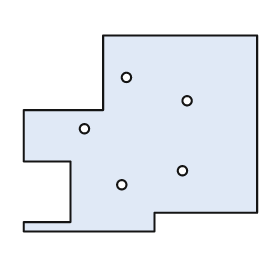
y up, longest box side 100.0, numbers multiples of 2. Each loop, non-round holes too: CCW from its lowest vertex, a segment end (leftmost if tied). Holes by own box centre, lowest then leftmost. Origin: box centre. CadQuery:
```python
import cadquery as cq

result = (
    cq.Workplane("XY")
    .moveTo(-50.0, -42.0)
    .lineTo(6.0, -42.0)
    .lineTo(6.0, -34.0)
    .lineTo(50.0, -34.0)
    .lineTo(50.0, 42.0)
    .lineTo(-16.0, 42.0)
    .lineTo(-16.0, 10.0)
    .lineTo(-50.0, 10.0)
    .lineTo(-50.0, -12.0)
    .lineTo(-30.0, -12.0)
    .lineTo(-30.0, -38.0)
    .lineTo(-50.0, -38.0)
    .close()
    .moveTo(-8.0, -22.0)
    .circle(2.0)
    .moveTo(18.0, -16.0)
    .circle(2.0)
    .moveTo(-24.0, 2.0)
    .circle(2.0)
    .moveTo(20.0, 14.0)
    .circle(2.0)
    .moveTo(-6.0, 24.0)
    .circle(2.0)
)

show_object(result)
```